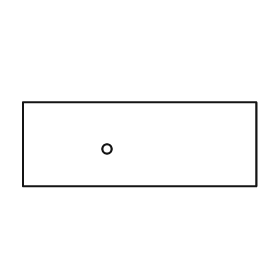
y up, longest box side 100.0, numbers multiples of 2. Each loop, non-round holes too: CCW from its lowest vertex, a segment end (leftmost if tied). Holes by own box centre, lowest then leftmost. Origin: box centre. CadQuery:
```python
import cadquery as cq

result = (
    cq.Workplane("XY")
    .moveTo(-50.0, -18.0)
    .lineTo(50.0, -18.0)
    .lineTo(50.0, 18.0)
    .lineTo(-50.0, 18.0)
    .close()
    .moveTo(-14.0, -2.0)
    .circle(2.0)
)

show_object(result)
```